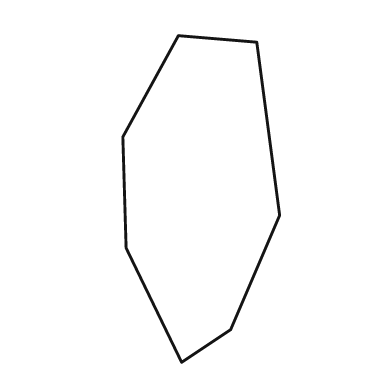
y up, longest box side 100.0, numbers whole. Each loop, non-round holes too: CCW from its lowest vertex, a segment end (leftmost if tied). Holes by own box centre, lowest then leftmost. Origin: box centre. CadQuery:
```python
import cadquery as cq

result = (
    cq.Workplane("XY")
    .moveTo(-6.0, -50.0)
    .lineTo(9.0, -40.0)
    .lineTo(24.0, -5.0)
    .lineTo(17.0, 48.0)
    .lineTo(-7.0, 50.0)
    .lineTo(-24.0, 19.0)
    .lineTo(-23.0, -15.0)
    .close()
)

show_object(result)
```